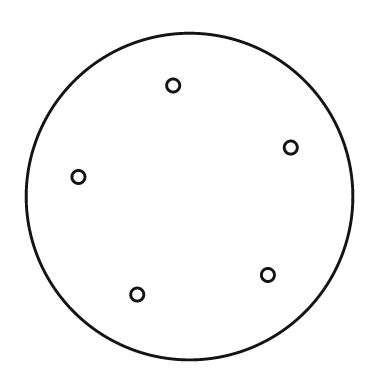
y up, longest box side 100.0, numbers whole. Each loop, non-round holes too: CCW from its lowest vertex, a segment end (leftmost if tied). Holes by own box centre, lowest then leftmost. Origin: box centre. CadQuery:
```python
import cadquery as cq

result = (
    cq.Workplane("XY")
    .moveTo(0.0, 0.0)
    .circle(50.0)
    .moveTo(-16.0, -30.0)
    .circle(2.0)
    .moveTo(24.0, -24.0)
    .circle(2.0)
    .moveTo(-34.0, 6.0)
    .circle(2.0)
    .moveTo(31.0, 15.0)
    .circle(2.0)
    .moveTo(-5.0, 34.0)
    .circle(2.0)
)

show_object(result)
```